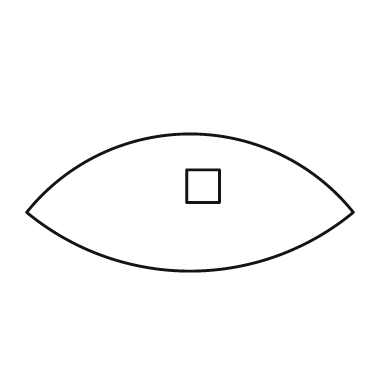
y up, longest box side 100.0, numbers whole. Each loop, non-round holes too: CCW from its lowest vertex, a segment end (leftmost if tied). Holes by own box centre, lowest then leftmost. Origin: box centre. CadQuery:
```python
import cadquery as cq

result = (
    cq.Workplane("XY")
    .moveTo(-50.0, -3.0)
    .threePointArc((0.0, -21.0), (50.0, -3.0))
    .threePointArc((0.0, 21.0), (-50.0, -3.0))
    .close()
    .moveTo(-1.0, 0.0)
    .lineTo(9.0, 0.0)
    .lineTo(9.0, 10.0)
    .lineTo(-1.0, 10.0)
    .close()
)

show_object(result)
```